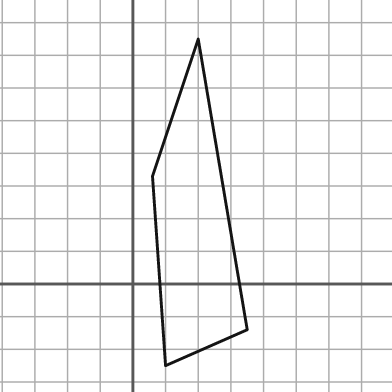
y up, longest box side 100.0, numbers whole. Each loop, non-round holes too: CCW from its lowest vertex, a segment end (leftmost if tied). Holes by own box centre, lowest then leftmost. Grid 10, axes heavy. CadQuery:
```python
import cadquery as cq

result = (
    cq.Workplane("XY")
    .moveTo(10.0, -25.0)
    .lineTo(35.0, -14.0)
    .lineTo(20.0, 75.0)
    .lineTo(6.0, 33.0)
    .close()
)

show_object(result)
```